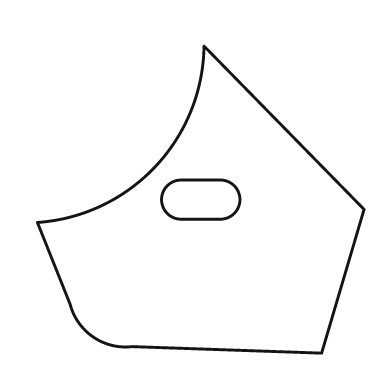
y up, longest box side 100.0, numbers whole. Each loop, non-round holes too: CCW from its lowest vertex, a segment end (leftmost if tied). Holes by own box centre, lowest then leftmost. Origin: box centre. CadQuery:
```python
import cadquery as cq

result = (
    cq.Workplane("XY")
    .moveTo(37.0, -47.0)
    .lineTo(50.0, -3.0)
    .lineTo(1.0, 47.0)
    .threePointArc((-14.0, 10.0), (-50.0, -7.0))
    .lineTo(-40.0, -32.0)
    .threePointArc((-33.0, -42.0), (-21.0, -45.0))
    .close()
    .moveTo(-6.0, -6.0)
    .lineTo(6.0, -6.0)
    .threePointArc((12.0, 0.0), (6.0, 6.0))
    .lineTo(-6.0, 6.0)
    .threePointArc((-12.0, 0.0), (-6.0, -6.0))
    .close()
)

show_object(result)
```